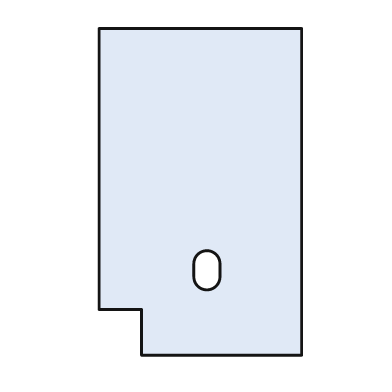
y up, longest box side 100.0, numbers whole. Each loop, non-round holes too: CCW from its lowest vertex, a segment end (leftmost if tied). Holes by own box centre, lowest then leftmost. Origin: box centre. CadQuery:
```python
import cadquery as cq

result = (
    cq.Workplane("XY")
    .moveTo(-18.0, -50.0)
    .lineTo(31.0, -50.0)
    .lineTo(31.0, 50.0)
    .lineTo(-31.0, 50.0)
    .lineTo(-31.0, -36.0)
    .lineTo(-18.0, -36.0)
    .close()
    .moveTo(-2.0, -26.0)
    .threePointArc((2.0, -30.0), (6.0, -26.0))
    .lineTo(6.0, -22.0)
    .threePointArc((2.0, -18.0), (-2.0, -22.0))
    .close()
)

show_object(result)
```